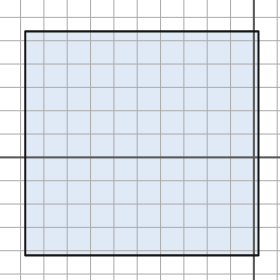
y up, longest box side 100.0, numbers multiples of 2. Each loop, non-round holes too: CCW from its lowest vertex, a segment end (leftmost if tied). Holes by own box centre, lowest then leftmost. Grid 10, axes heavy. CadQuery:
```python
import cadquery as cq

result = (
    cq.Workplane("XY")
    .moveTo(-98.0, -42.0)
    .lineTo(2.0, -42.0)
    .lineTo(2.0, 54.0)
    .lineTo(-98.0, 54.0)
    .close()
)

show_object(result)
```